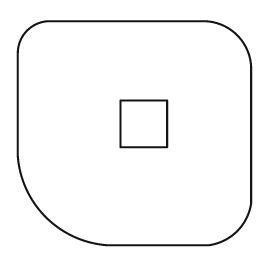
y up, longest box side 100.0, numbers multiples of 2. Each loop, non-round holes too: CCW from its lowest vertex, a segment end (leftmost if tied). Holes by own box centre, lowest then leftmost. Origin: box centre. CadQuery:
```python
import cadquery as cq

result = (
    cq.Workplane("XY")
    .moveTo(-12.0, -48.0)
    .lineTo(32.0, -48.0)
    .threePointArc((44.0, -42.0), (50.0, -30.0))
    .lineTo(50.0, 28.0)
    .threePointArc((44.0, 42.0), (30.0, 48.0))
    .lineTo(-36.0, 48.0)
    .threePointArc((-46.0, 44.0), (-50.0, 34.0))
    .lineTo(-50.0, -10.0)
    .threePointArc((-38.0, -36.0), (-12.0, -48.0))
    .close()
    .moveTo(-6.0, -6.0)
    .lineTo(14.0, -6.0)
    .lineTo(14.0, 14.0)
    .lineTo(-6.0, 14.0)
    .close()
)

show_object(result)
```